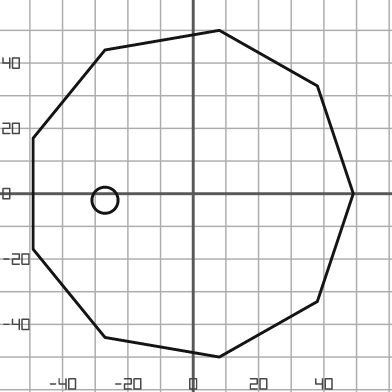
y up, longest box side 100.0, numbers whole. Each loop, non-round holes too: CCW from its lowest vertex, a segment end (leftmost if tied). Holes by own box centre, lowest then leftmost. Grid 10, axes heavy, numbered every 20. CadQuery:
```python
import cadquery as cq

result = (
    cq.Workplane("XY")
    .moveTo(8.0, -50.0)
    .lineTo(38.0, -33.0)
    .lineTo(49.0, 0.0)
    .lineTo(38.0, 33.0)
    .lineTo(8.0, 50.0)
    .lineTo(-27.0, 44.0)
    .lineTo(-49.0, 17.0)
    .lineTo(-49.0, -17.0)
    .lineTo(-27.0, -44.0)
    .close()
    .moveTo(-27.0, -2.0)
    .circle(4.0)
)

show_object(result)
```